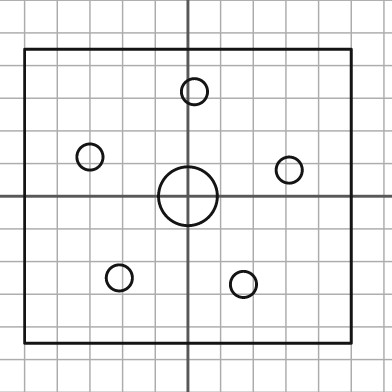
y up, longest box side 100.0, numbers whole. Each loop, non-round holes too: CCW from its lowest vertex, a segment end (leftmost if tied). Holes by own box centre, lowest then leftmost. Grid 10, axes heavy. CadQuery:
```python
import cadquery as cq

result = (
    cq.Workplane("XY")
    .moveTo(-50.0, -45.0)
    .lineTo(50.0, -45.0)
    .lineTo(50.0, 45.0)
    .lineTo(-50.0, 45.0)
    .close()
    .moveTo(17.0, -27.0)
    .circle(4.0)
    .moveTo(-21.0, -25.0)
    .circle(4.0)
    .moveTo(0.0, 0.0)
    .circle(9.0)
    .moveTo(31.0, 8.0)
    .circle(4.0)
    .moveTo(-30.0, 12.0)
    .circle(4.0)
    .moveTo(2.0, 32.0)
    .circle(4.0)
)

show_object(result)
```